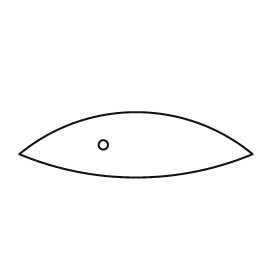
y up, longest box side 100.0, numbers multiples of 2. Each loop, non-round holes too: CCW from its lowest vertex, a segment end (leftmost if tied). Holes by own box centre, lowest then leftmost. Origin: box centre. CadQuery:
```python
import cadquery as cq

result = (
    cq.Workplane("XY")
    .moveTo(-50.0, -4.0)
    .threePointArc((0.0, -14.0), (50.0, -4.0))
    .threePointArc((0.0, 14.0), (-50.0, -4.0))
    .close()
    .moveTo(-14.0, 0.0)
    .circle(2.0)
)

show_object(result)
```